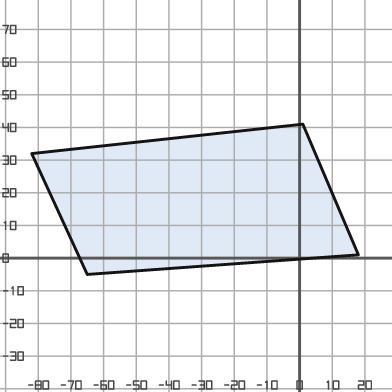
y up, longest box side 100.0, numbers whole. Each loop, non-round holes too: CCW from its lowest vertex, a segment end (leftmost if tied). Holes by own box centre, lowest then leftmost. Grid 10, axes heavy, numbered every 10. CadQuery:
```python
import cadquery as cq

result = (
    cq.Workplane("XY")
    .moveTo(-65.0, -5.0)
    .lineTo(18.0, 1.0)
    .lineTo(1.0, 41.0)
    .lineTo(-82.0, 32.0)
    .close()
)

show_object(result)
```